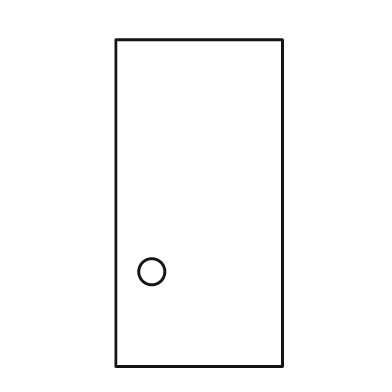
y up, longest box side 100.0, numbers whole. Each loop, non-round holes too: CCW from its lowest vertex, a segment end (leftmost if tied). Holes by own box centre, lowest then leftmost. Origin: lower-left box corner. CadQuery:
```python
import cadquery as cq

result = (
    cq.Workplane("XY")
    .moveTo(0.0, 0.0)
    .lineTo(51.0, 0.0)
    .lineTo(51.0, 100.0)
    .lineTo(0.0, 100.0)
    .close()
    .moveTo(11.0, 29.0)
    .circle(4.0)
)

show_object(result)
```